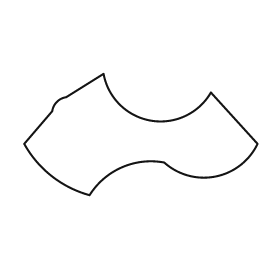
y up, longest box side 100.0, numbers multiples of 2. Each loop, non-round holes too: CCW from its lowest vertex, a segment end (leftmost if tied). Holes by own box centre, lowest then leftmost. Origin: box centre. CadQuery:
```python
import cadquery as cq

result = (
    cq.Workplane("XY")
    .moveTo(-22.0, -26.0)
    .threePointArc((-8.0, -14.0), (10.0, -12.0))
    .threePointArc((32.0, -18.0), (50.0, -4.0))
    .lineTo(30.0, 18.0)
    .threePointArc((4.0, 6.0), (-16.0, 26.0))
    .lineTo(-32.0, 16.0)
    .threePointArc((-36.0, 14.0), (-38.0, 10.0))
    .lineTo(-50.0, -4.0)
    .threePointArc((-38.0, -18.0), (-22.0, -26.0))
    .close()
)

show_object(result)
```